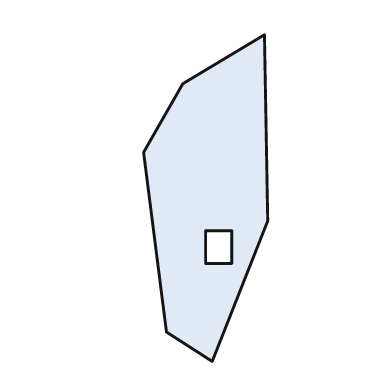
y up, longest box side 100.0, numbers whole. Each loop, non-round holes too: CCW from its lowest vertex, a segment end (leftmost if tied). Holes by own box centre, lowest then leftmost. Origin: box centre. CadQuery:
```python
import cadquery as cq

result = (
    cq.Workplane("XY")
    .moveTo(2.0, -50.0)
    .lineTo(19.0, -7.0)
    .lineTo(18.0, 50.0)
    .lineTo(-7.0, 35.0)
    .lineTo(-19.0, 14.0)
    .lineTo(-12.0, -41.0)
    .close()
    .moveTo(0.0, -20.0)
    .lineTo(8.0, -20.0)
    .lineTo(8.0, -10.0)
    .lineTo(0.0, -10.0)
    .close()
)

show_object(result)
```